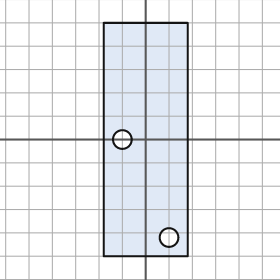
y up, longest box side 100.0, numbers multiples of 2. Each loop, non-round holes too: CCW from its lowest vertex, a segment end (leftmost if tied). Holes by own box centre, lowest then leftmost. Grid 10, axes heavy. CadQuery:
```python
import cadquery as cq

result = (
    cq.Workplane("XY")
    .moveTo(-18.0, -50.0)
    .lineTo(18.0, -50.0)
    .lineTo(18.0, 50.0)
    .lineTo(-18.0, 50.0)
    .close()
    .moveTo(10.0, -42.0)
    .circle(4.0)
    .moveTo(-10.0, 0.0)
    .circle(4.0)
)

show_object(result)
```